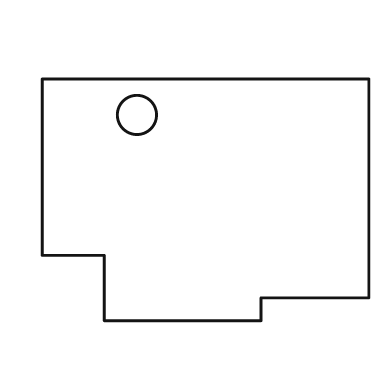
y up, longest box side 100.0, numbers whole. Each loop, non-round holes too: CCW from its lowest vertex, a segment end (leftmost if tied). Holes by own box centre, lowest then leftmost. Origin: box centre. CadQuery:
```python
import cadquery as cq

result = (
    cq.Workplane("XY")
    .moveTo(-31.0, -37.0)
    .lineTo(17.0, -37.0)
    .lineTo(17.0, -30.0)
    .lineTo(50.0, -30.0)
    .lineTo(50.0, 37.0)
    .lineTo(-50.0, 37.0)
    .lineTo(-50.0, -17.0)
    .lineTo(-31.0, -17.0)
    .close()
    .moveTo(-21.0, 26.0)
    .circle(6.0)
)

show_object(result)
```